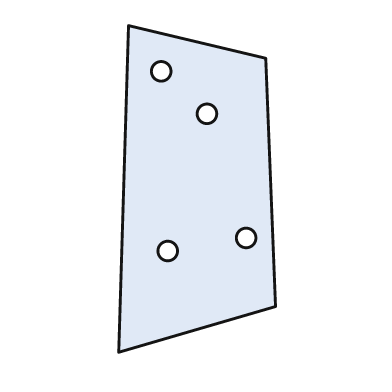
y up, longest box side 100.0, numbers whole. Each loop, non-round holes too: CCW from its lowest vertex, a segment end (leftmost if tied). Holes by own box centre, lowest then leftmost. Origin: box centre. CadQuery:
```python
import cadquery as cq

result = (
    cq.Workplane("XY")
    .moveTo(-24.0, -50.0)
    .lineTo(24.0, -36.0)
    .lineTo(21.0, 40.0)
    .lineTo(-21.0, 50.0)
    .close()
    .moveTo(-9.0, -19.0)
    .circle(3.0)
    .moveTo(15.0, -15.0)
    .circle(3.0)
    .moveTo(3.0, 23.0)
    .circle(3.0)
    .moveTo(-11.0, 36.0)
    .circle(3.0)
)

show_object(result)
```